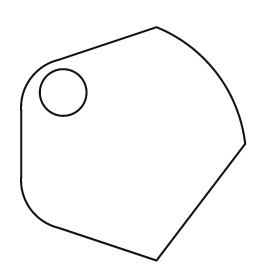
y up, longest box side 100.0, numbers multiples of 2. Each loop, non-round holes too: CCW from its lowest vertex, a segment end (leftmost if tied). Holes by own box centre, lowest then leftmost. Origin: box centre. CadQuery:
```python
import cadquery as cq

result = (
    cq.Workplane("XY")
    .moveTo(10.0, -50.0)
    .lineTo(48.0, 0.0)
    .threePointArc((36.0, 30.0), (10.0, 50.0))
    .lineTo(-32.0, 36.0)
    .threePointArc((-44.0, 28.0), (-48.0, 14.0))
    .lineTo(-48.0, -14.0)
    .threePointArc((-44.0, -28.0), (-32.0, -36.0))
    .close()
    .moveTo(-30.0, 22.0)
    .circle(10.0)
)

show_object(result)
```